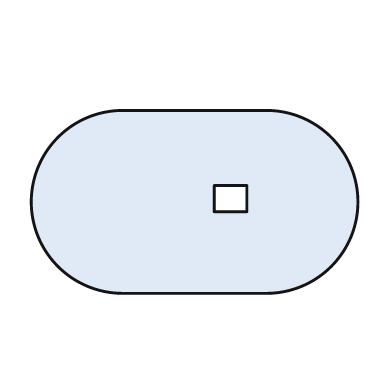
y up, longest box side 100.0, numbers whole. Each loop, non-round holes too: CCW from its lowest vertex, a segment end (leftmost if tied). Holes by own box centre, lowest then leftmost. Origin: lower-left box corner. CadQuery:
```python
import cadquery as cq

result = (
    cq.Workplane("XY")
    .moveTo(28.0, 0.0)
    .lineTo(72.0, 0.0)
    .threePointArc((100.0, 28.0), (72.0, 56.0))
    .lineTo(28.0, 56.0)
    .threePointArc((0.0, 28.0), (28.0, 0.0))
    .close()
    .moveTo(56.0, 25.0)
    .lineTo(66.0, 25.0)
    .lineTo(66.0, 33.0)
    .lineTo(56.0, 33.0)
    .close()
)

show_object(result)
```